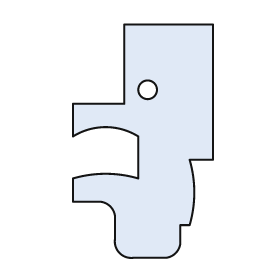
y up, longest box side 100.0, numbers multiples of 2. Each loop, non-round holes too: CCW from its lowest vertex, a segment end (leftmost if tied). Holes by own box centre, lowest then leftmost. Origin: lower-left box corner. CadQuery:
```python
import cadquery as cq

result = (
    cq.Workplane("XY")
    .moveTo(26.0, 0.0)
    .lineTo(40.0, 0.0)
    .threePointArc((44.0, 2.0), (46.0, 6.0))
    .lineTo(46.0, 14.0)
    .lineTo(50.0, 14.0)
    .threePointArc((52.0, 28.0), (50.0, 42.0))
    .lineTo(60.0, 42.0)
    .lineTo(60.0, 100.0)
    .lineTo(22.0, 100.0)
    .lineTo(22.0, 66.0)
    .lineTo(0.0, 66.0)
    .lineTo(0.0, 52.0)
    .threePointArc((14.0, 56.0), (28.0, 52.0))
    .lineTo(28.0, 34.0)
    .threePointArc((14.0, 36.0), (0.0, 34.0))
    .lineTo(0.0, 24.0)
    .lineTo(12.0, 24.0)
    .threePointArc((16.0, 22.0), (18.0, 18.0))
    .lineTo(18.0, 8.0)
    .threePointArc((20.0, 2.0), (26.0, 0.0))
    .close()
    .moveTo(32.0, 72.0)
    .circle(4.0)
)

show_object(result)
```